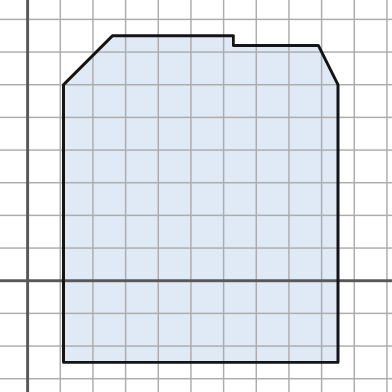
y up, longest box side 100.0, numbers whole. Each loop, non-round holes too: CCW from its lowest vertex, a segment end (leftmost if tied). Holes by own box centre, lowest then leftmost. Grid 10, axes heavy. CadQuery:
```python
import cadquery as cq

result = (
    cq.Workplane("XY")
    .moveTo(11.0, -25.0)
    .lineTo(95.0, -25.0)
    .lineTo(95.0, 60.0)
    .lineTo(89.0, 72.0)
    .lineTo(63.0, 72.0)
    .lineTo(63.0, 75.0)
    .lineTo(26.0, 75.0)
    .lineTo(11.0, 60.0)
    .close()
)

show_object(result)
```